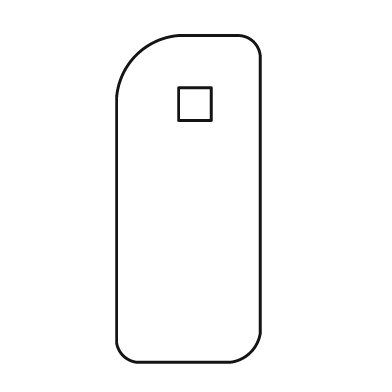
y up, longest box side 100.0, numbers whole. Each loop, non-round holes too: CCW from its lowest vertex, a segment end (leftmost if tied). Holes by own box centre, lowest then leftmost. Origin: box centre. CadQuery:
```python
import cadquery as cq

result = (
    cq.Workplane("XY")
    .moveTo(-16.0, -50.0)
    .lineTo(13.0, -50.0)
    .threePointArc((19.0, -47.0), (22.0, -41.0))
    .lineTo(22.0, 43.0)
    .threePointArc((20.0, 48.0), (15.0, 50.0))
    .lineTo(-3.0, 50.0)
    .threePointArc((-16.0, 44.0), (-22.0, 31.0))
    .lineTo(-22.0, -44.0)
    .threePointArc((-20.0, -48.0), (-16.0, -50.0))
    .close()
    .moveTo(-3.0, 24.0)
    .lineTo(7.0, 24.0)
    .lineTo(7.0, 34.0)
    .lineTo(-3.0, 34.0)
    .close()
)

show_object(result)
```